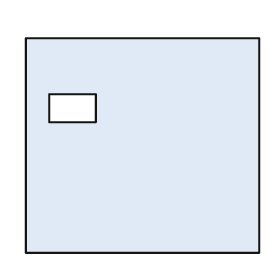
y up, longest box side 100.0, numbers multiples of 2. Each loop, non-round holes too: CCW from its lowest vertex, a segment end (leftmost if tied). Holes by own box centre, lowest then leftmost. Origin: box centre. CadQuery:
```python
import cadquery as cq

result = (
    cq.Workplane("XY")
    .moveTo(-50.0, -46.0)
    .lineTo(50.0, -46.0)
    .lineTo(50.0, 46.0)
    .lineTo(-50.0, 46.0)
    .close()
    .moveTo(-40.0, 10.0)
    .lineTo(-20.0, 10.0)
    .lineTo(-20.0, 22.0)
    .lineTo(-40.0, 22.0)
    .close()
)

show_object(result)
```